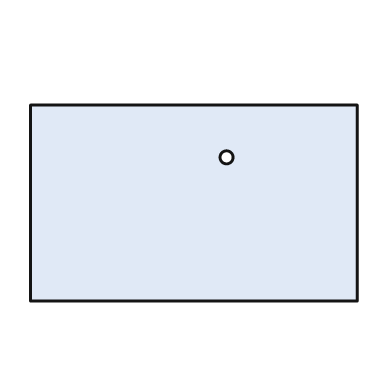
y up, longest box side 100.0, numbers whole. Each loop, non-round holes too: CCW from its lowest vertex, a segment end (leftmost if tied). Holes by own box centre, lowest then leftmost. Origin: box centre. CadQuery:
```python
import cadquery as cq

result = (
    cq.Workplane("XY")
    .moveTo(-50.0, -30.0)
    .lineTo(50.0, -30.0)
    .lineTo(50.0, 30.0)
    .lineTo(-50.0, 30.0)
    .close()
    .moveTo(10.0, 14.0)
    .circle(2.0)
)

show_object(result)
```